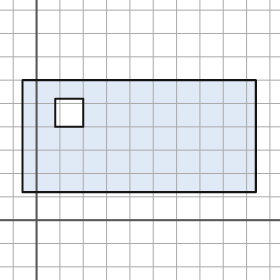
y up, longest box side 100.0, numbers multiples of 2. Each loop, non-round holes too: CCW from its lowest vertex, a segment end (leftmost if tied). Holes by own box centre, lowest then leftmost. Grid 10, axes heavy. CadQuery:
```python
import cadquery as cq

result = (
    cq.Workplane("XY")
    .moveTo(-6.0, 12.0)
    .lineTo(94.0, 12.0)
    .lineTo(94.0, 60.0)
    .lineTo(-6.0, 60.0)
    .close()
    .moveTo(8.0, 40.0)
    .lineTo(20.0, 40.0)
    .lineTo(20.0, 52.0)
    .lineTo(8.0, 52.0)
    .close()
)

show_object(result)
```